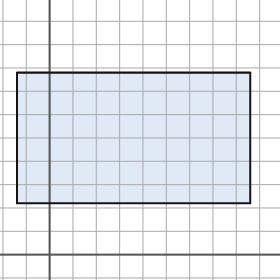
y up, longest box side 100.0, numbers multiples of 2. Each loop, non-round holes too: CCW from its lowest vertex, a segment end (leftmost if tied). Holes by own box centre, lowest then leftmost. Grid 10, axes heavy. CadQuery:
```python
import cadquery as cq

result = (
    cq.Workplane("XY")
    .moveTo(-14.0, 22.0)
    .lineTo(86.0, 22.0)
    .lineTo(86.0, 78.0)
    .lineTo(-14.0, 78.0)
    .close()
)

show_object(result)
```